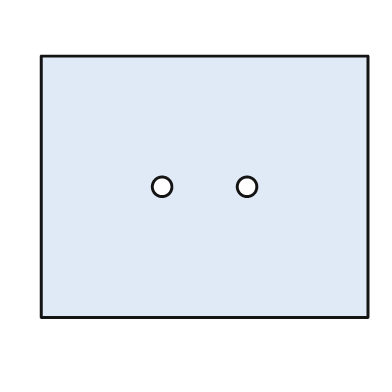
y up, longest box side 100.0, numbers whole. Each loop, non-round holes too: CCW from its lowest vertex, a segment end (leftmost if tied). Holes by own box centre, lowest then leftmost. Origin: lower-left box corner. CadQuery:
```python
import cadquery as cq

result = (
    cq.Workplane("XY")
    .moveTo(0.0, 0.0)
    .lineTo(100.0, 0.0)
    .lineTo(100.0, 80.0)
    .lineTo(0.0, 80.0)
    .close()
    .moveTo(37.0, 40.0)
    .circle(3.0)
    .moveTo(63.0, 40.0)
    .circle(3.0)
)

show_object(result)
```